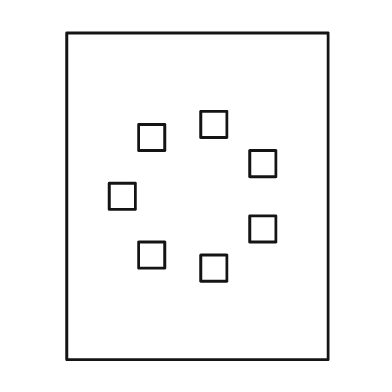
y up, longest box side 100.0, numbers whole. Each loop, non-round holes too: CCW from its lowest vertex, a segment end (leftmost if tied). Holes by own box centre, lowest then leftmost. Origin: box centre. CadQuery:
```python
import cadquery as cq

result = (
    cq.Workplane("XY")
    .moveTo(-40.0, -50.0)
    .lineTo(40.0, -50.0)
    .lineTo(40.0, 50.0)
    .lineTo(-40.0, 50.0)
    .close()
    .moveTo(1.0, -26.0)
    .lineTo(9.0, -26.0)
    .lineTo(9.0, -18.0)
    .lineTo(1.0, -18.0)
    .close()
    .moveTo(-18.0, -22.0)
    .lineTo(-10.0, -22.0)
    .lineTo(-10.0, -14.0)
    .lineTo(-18.0, -14.0)
    .close()
    .moveTo(16.0, -14.0)
    .lineTo(24.0, -14.0)
    .lineTo(24.0, -6.0)
    .lineTo(16.0, -6.0)
    .close()
    .moveTo(-27.0, -4.0)
    .lineTo(-19.0, -4.0)
    .lineTo(-19.0, 4.0)
    .lineTo(-27.0, 4.0)
    .close()
    .moveTo(16.0, 6.0)
    .lineTo(24.0, 6.0)
    .lineTo(24.0, 14.0)
    .lineTo(16.0, 14.0)
    .close()
    .moveTo(-18.0, 14.0)
    .lineTo(-10.0, 14.0)
    .lineTo(-10.0, 22.0)
    .lineTo(-18.0, 22.0)
    .close()
    .moveTo(1.0, 18.0)
    .lineTo(9.0, 18.0)
    .lineTo(9.0, 26.0)
    .lineTo(1.0, 26.0)
    .close()
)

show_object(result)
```